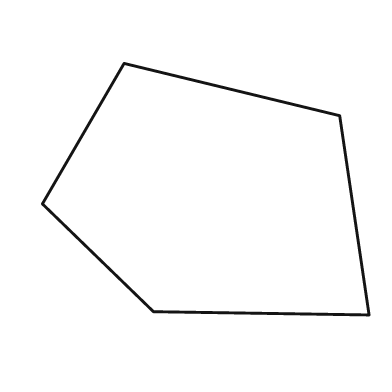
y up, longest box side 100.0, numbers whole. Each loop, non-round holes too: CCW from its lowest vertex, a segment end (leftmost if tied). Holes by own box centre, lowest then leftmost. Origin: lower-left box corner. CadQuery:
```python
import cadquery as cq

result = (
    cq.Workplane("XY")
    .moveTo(100.0, 0.0)
    .lineTo(91.0, 61.0)
    .lineTo(25.0, 77.0)
    .lineTo(0.0, 34.0)
    .lineTo(34.0, 1.0)
    .close()
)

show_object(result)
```